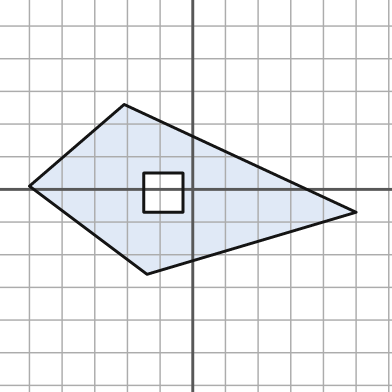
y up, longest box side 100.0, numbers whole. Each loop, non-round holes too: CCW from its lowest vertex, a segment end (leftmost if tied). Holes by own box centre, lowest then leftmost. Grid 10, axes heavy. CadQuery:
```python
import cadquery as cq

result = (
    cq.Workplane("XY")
    .moveTo(-14.0, -26.0)
    .lineTo(50.0, -7.0)
    .lineTo(-21.0, 26.0)
    .lineTo(-50.0, 1.0)
    .close()
    .moveTo(-15.0, -7.0)
    .lineTo(-3.0, -7.0)
    .lineTo(-3.0, 5.0)
    .lineTo(-15.0, 5.0)
    .close()
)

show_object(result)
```